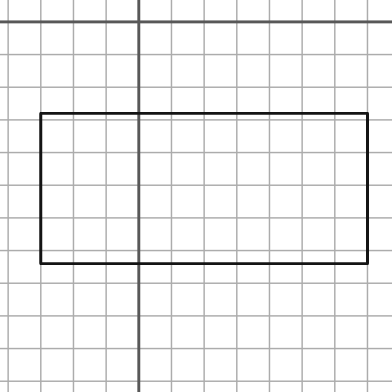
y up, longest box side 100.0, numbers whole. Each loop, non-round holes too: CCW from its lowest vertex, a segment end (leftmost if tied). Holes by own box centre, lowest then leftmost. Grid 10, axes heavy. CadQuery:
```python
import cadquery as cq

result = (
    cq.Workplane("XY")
    .moveTo(-30.0, -74.0)
    .lineTo(70.0, -74.0)
    .lineTo(70.0, -28.0)
    .lineTo(-30.0, -28.0)
    .close()
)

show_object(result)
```